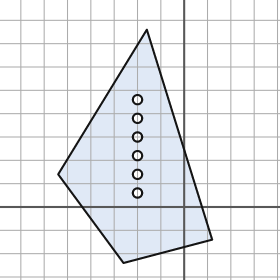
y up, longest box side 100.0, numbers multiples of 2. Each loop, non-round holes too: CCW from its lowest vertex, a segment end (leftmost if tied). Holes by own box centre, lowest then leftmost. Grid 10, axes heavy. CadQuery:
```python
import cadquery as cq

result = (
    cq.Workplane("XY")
    .moveTo(-26.0, -24.0)
    .lineTo(12.0, -14.0)
    .lineTo(-16.0, 76.0)
    .lineTo(-54.0, 14.0)
    .close()
    .moveTo(-20.0, 6.0)
    .circle(2.0)
    .moveTo(-20.0, 14.0)
    .circle(2.0)
    .moveTo(-20.0, 22.0)
    .circle(2.0)
    .moveTo(-20.0, 30.0)
    .circle(2.0)
    .moveTo(-20.0, 38.0)
    .circle(2.0)
    .moveTo(-20.0, 46.0)
    .circle(2.0)
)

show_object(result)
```